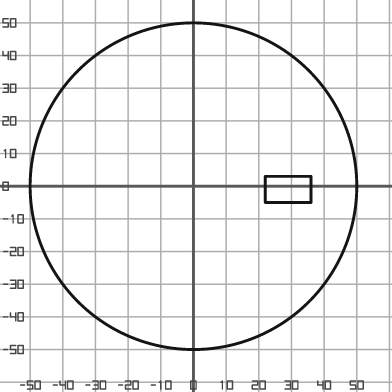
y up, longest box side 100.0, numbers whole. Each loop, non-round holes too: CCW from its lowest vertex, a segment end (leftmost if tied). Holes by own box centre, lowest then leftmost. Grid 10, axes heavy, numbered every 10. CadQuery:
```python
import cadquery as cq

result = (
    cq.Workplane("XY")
    .moveTo(0.0, 0.0)
    .circle(50.0)
    .moveTo(22.0, -5.0)
    .lineTo(36.0, -5.0)
    .lineTo(36.0, 3.0)
    .lineTo(22.0, 3.0)
    .close()
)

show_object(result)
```